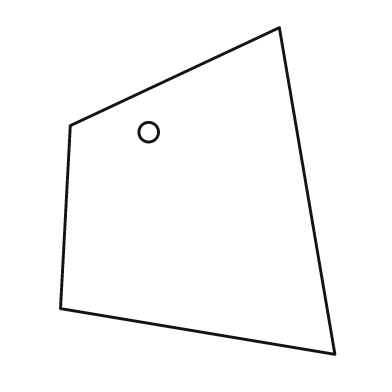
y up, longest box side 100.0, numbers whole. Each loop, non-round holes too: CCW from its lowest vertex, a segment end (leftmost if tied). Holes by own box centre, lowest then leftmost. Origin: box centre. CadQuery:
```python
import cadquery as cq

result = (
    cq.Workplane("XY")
    .moveTo(42.0, -50.0)
    .lineTo(25.0, 50.0)
    .lineTo(-39.0, 20.0)
    .lineTo(-42.0, -36.0)
    .close()
    .moveTo(-15.0, 18.0)
    .circle(3.0)
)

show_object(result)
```